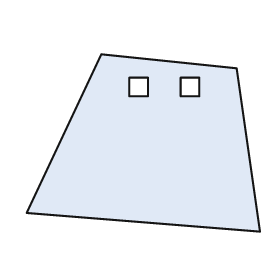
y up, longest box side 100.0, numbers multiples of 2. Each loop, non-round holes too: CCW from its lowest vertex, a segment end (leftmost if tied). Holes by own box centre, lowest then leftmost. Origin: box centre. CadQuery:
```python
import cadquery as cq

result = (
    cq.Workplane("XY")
    .moveTo(50.0, -38.0)
    .lineTo(40.0, 32.0)
    .lineTo(-18.0, 38.0)
    .lineTo(-50.0, -30.0)
    .close()
    .moveTo(-6.0, 20.0)
    .lineTo(2.0, 20.0)
    .lineTo(2.0, 28.0)
    .lineTo(-6.0, 28.0)
    .close()
    .moveTo(16.0, 20.0)
    .lineTo(24.0, 20.0)
    .lineTo(24.0, 28.0)
    .lineTo(16.0, 28.0)
    .close()
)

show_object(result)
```